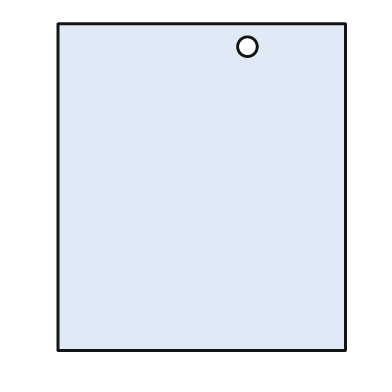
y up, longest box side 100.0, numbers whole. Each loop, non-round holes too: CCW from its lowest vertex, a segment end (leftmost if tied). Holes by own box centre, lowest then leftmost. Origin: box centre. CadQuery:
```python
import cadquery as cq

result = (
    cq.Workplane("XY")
    .moveTo(-44.0, -50.0)
    .lineTo(44.0, -50.0)
    .lineTo(44.0, 50.0)
    .lineTo(-44.0, 50.0)
    .close()
    .moveTo(14.0, 43.0)
    .circle(3.0)
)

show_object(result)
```